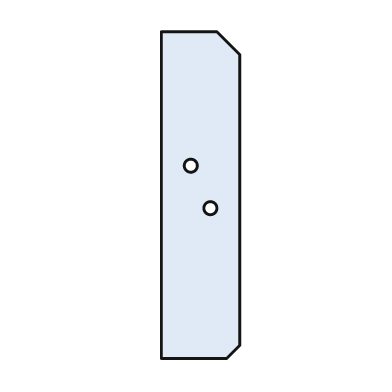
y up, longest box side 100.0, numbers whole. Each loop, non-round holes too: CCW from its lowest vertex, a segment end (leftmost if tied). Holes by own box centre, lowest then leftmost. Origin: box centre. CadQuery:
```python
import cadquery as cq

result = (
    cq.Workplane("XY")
    .moveTo(-12.0, -50.0)
    .lineTo(8.0, -50.0)
    .lineTo(12.0, -46.0)
    .lineTo(12.0, 43.0)
    .lineTo(5.0, 50.0)
    .lineTo(-12.0, 50.0)
    .close()
    .moveTo(3.0, -4.0)
    .circle(2.0)
    .moveTo(-3.0, 9.0)
    .circle(2.0)
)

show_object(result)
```